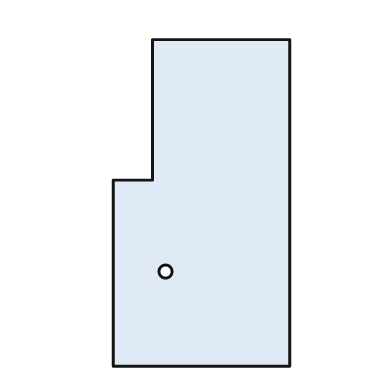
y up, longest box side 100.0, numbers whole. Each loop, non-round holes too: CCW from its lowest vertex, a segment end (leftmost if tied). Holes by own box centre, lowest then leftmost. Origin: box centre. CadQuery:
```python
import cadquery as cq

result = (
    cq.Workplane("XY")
    .moveTo(-27.0, -50.0)
    .lineTo(27.0, -50.0)
    .lineTo(27.0, 50.0)
    .lineTo(-15.0, 50.0)
    .lineTo(-15.0, 7.0)
    .lineTo(-27.0, 7.0)
    .close()
    .moveTo(-11.0, -21.0)
    .circle(2.0)
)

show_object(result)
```